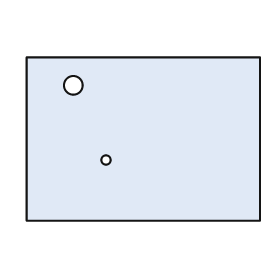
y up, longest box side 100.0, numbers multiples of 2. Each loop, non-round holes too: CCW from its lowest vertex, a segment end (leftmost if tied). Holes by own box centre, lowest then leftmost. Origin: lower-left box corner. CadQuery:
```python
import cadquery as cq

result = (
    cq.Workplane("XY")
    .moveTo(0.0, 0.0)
    .lineTo(100.0, 0.0)
    .lineTo(100.0, 70.0)
    .lineTo(0.0, 70.0)
    .close()
    .moveTo(34.0, 26.0)
    .circle(2.0)
    .moveTo(20.0, 58.0)
    .circle(4.0)
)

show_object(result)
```